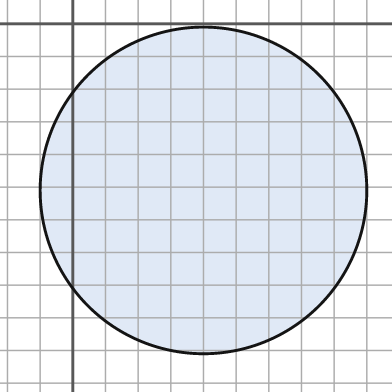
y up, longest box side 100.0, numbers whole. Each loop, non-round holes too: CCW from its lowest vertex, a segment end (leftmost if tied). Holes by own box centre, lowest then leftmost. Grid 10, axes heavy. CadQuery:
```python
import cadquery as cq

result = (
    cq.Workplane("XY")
    .moveTo(40.0, -51.0)
    .circle(50.0)
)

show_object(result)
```